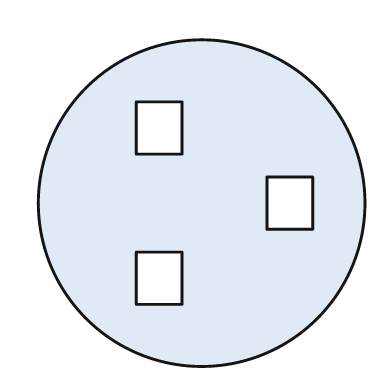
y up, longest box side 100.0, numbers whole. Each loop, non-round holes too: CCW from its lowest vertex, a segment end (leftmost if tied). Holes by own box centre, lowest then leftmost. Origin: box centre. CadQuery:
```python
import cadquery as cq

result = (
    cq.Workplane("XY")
    .moveTo(0.0, 0.0)
    .circle(50.0)
    .moveTo(-20.0, -31.0)
    .lineTo(-6.0, -31.0)
    .lineTo(-6.0, -15.0)
    .lineTo(-20.0, -15.0)
    .close()
    .moveTo(20.0, -8.0)
    .lineTo(34.0, -8.0)
    .lineTo(34.0, 8.0)
    .lineTo(20.0, 8.0)
    .close()
    .moveTo(-20.0, 15.0)
    .lineTo(-6.0, 15.0)
    .lineTo(-6.0, 31.0)
    .lineTo(-20.0, 31.0)
    .close()
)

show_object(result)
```